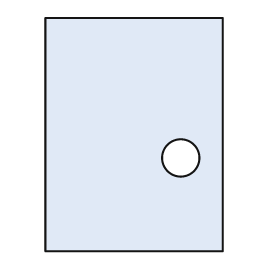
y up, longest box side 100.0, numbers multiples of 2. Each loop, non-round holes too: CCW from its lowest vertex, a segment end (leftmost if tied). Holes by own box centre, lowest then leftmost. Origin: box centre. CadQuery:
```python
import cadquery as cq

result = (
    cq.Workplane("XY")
    .moveTo(-38.0, -50.0)
    .lineTo(38.0, -50.0)
    .lineTo(38.0, 50.0)
    .lineTo(-38.0, 50.0)
    .close()
    .moveTo(20.0, -10.0)
    .circle(8.0)
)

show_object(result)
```